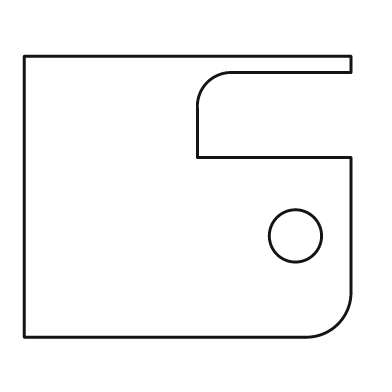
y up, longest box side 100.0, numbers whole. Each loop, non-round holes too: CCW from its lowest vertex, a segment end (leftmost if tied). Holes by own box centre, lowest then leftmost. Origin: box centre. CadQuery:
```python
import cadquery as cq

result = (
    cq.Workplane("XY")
    .moveTo(-50.0, -43.0)
    .lineTo(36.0, -43.0)
    .threePointArc((46.0, -39.0), (50.0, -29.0))
    .lineTo(50.0, 12.0)
    .lineTo(3.0, 12.0)
    .lineTo(3.0, 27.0)
    .threePointArc((6.0, 35.0), (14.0, 38.0))
    .lineTo(50.0, 38.0)
    .lineTo(50.0, 43.0)
    .lineTo(-50.0, 43.0)
    .close()
    .moveTo(33.0, -12.0)
    .circle(8.0)
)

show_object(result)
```